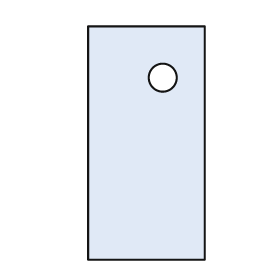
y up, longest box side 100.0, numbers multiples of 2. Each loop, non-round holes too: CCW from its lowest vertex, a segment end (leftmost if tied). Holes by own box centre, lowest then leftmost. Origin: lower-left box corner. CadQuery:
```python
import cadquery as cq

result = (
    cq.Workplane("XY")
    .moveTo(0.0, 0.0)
    .lineTo(50.0, 0.0)
    .lineTo(50.0, 100.0)
    .lineTo(0.0, 100.0)
    .close()
    .moveTo(32.0, 78.0)
    .circle(6.0)
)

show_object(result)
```